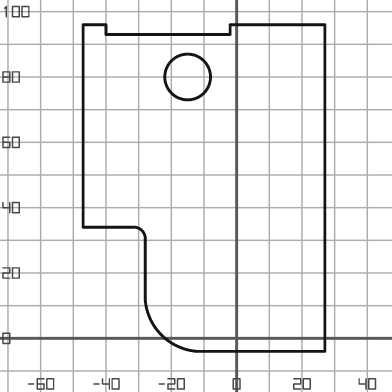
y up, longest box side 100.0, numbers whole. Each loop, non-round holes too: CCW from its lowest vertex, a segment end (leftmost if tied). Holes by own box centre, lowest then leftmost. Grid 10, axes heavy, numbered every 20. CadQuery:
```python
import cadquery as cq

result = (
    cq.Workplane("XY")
    .moveTo(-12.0, -4.0)
    .lineTo(27.0, -4.0)
    .lineTo(27.0, 96.0)
    .lineTo(-2.0, 96.0)
    .lineTo(-2.0, 93.0)
    .lineTo(-40.0, 93.0)
    .lineTo(-40.0, 96.0)
    .lineTo(-47.0, 96.0)
    .lineTo(-47.0, 34.0)
    .lineTo(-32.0, 34.0)
    .threePointArc((-29.0, 33.0), (-28.0, 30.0))
    .lineTo(-28.0, 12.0)
    .threePointArc((-23.0, 1.0), (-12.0, -4.0))
    .close()
    .moveTo(-15.0, 80.0)
    .circle(7.0)
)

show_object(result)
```